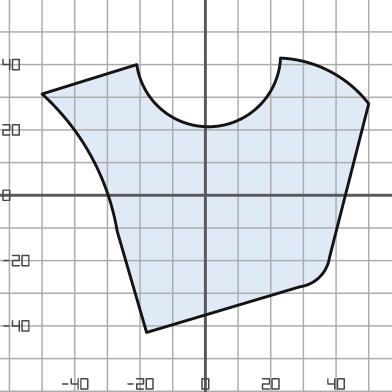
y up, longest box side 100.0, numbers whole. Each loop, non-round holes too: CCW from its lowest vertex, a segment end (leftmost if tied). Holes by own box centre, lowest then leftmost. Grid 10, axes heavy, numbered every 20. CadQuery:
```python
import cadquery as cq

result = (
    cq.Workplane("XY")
    .moveTo(-18.0, -42.0)
    .lineTo(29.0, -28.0)
    .threePointArc((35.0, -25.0), (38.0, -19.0))
    .lineTo(50.0, 28.0)
    .threePointArc((38.0, 38.0), (23.0, 42.0))
    .threePointArc((2.0, 21.0), (-21.0, 40.0))
    .lineTo(-50.0, 31.0)
    .threePointArc((-35.0, 12.0), (-27.0, -11.0))
    .close()
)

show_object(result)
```